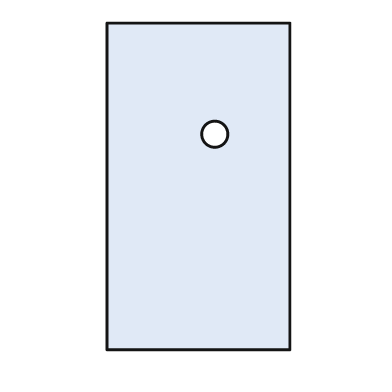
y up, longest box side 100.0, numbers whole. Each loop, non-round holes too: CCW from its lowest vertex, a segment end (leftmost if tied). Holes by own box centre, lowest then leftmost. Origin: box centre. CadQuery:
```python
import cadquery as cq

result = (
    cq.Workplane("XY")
    .moveTo(-28.0, -50.0)
    .lineTo(28.0, -50.0)
    .lineTo(28.0, 50.0)
    .lineTo(-28.0, 50.0)
    .close()
    .moveTo(5.0, 16.0)
    .circle(4.0)
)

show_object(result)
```